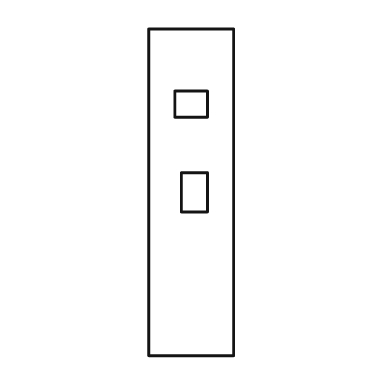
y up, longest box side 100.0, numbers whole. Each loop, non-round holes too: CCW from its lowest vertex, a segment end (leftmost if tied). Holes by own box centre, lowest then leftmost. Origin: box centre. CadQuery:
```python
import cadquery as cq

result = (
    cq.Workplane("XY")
    .moveTo(-13.0, -50.0)
    .lineTo(13.0, -50.0)
    .lineTo(13.0, 50.0)
    .lineTo(-13.0, 50.0)
    .close()
    .moveTo(-3.0, -6.0)
    .lineTo(5.0, -6.0)
    .lineTo(5.0, 6.0)
    .lineTo(-3.0, 6.0)
    .close()
    .moveTo(-5.0, 23.0)
    .lineTo(5.0, 23.0)
    .lineTo(5.0, 31.0)
    .lineTo(-5.0, 31.0)
    .close()
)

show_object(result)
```